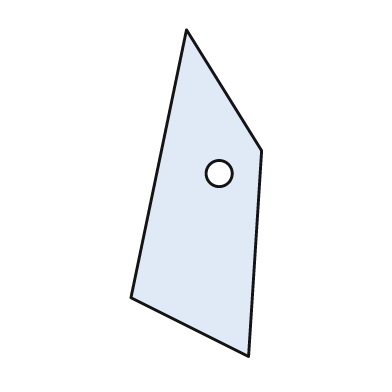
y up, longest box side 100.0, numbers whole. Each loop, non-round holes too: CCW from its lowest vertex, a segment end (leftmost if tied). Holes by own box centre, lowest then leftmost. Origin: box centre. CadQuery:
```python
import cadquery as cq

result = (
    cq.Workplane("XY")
    .moveTo(16.0, -50.0)
    .lineTo(20.0, 13.0)
    .lineTo(-3.0, 50.0)
    .lineTo(-20.0, -32.0)
    .close()
    .moveTo(7.0, 6.0)
    .circle(4.0)
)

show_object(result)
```